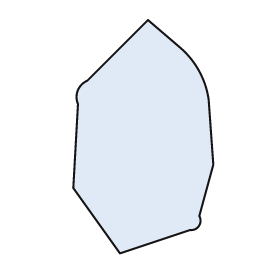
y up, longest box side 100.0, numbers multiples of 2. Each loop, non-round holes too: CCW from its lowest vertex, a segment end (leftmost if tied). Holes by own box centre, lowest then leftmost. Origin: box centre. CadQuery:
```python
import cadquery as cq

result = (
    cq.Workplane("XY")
    .moveTo(-10.0, -50.0)
    .lineTo(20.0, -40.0)
    .threePointArc((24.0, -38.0), (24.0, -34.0))
    .lineTo(30.0, -12.0)
    .lineTo(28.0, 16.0)
    .threePointArc((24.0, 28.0), (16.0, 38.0))
    .lineTo(2.0, 50.0)
    .lineTo(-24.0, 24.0)
    .threePointArc((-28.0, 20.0), (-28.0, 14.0))
    .lineTo(-30.0, -22.0)
    .close()
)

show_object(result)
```